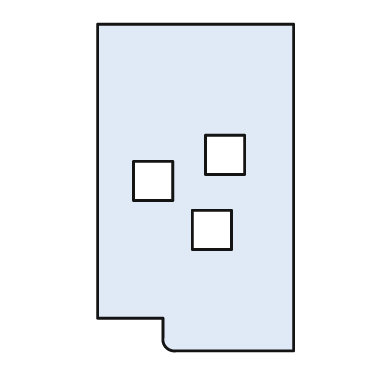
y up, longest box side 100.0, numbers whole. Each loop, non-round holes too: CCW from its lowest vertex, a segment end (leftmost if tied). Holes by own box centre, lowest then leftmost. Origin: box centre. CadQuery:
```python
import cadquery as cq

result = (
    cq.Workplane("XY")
    .moveTo(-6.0, -50.0)
    .lineTo(30.0, -50.0)
    .lineTo(30.0, 50.0)
    .lineTo(-30.0, 50.0)
    .lineTo(-30.0, -40.0)
    .lineTo(-10.0, -40.0)
    .lineTo(-10.0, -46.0)
    .threePointArc((-9.0, -49.0), (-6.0, -50.0))
    .close()
    .moveTo(-1.0, -19.0)
    .lineTo(11.0, -19.0)
    .lineTo(11.0, -7.0)
    .lineTo(-1.0, -7.0)
    .close()
    .moveTo(-19.0, -4.0)
    .lineTo(-7.0, -4.0)
    .lineTo(-7.0, 8.0)
    .lineTo(-19.0, 8.0)
    .close()
    .moveTo(3.0, 4.0)
    .lineTo(15.0, 4.0)
    .lineTo(15.0, 16.0)
    .lineTo(3.0, 16.0)
    .close()
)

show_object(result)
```